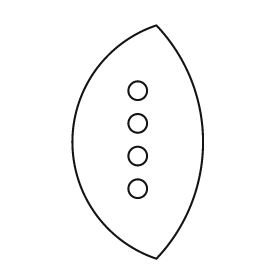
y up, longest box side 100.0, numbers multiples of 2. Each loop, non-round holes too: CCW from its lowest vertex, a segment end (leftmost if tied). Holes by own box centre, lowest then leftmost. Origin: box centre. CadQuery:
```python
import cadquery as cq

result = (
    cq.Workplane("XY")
    .moveTo(8.0, -50.0)
    .threePointArc((28.0, 0.0), (8.0, 50.0))
    .threePointArc((-28.0, 0.0), (8.0, -50.0))
    .close()
    .moveTo(0.0, -20.0)
    .circle(4.0)
    .moveTo(0.0, -6.0)
    .circle(4.0)
    .moveTo(0.0, 8.0)
    .circle(4.0)
    .moveTo(0.0, 22.0)
    .circle(4.0)
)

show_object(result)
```